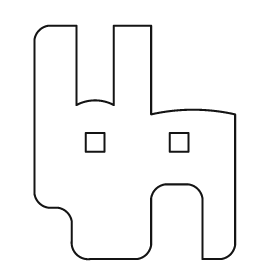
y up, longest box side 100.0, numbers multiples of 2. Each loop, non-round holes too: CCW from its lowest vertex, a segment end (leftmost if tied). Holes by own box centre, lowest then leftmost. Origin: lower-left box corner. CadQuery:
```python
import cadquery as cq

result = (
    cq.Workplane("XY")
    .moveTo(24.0, 0.0)
    .lineTo(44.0, 0.0)
    .threePointArc((48.0, 2.0), (50.0, 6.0))
    .lineTo(50.0, 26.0)
    .threePointArc((52.0, 30.0), (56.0, 32.0))
    .lineTo(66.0, 32.0)
    .threePointArc((70.0, 30.0), (72.0, 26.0))
    .lineTo(72.0, 0.0)
    .lineTo(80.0, 0.0)
    .threePointArc((84.0, 2.0), (86.0, 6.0))
    .lineTo(86.0, 62.0)
    .threePointArc((68.0, 64.0), (50.0, 62.0))
    .lineTo(50.0, 100.0)
    .lineTo(34.0, 100.0)
    .lineTo(34.0, 66.0)
    .threePointArc((26.0, 68.0), (18.0, 66.0))
    .lineTo(18.0, 100.0)
    .lineTo(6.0, 100.0)
    .threePointArc((2.0, 98.0), (0.0, 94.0))
    .lineTo(0.0, 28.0)
    .threePointArc((2.0, 24.0), (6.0, 22.0))
    .lineTo(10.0, 22.0)
    .threePointArc((14.0, 20.0), (16.0, 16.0))
    .lineTo(16.0, 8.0)
    .threePointArc((18.0, 2.0), (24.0, 0.0))
    .close()
    .moveTo(22.0, 46.0)
    .lineTo(30.0, 46.0)
    .lineTo(30.0, 54.0)
    .lineTo(22.0, 54.0)
    .close()
    .moveTo(58.0, 46.0)
    .lineTo(66.0, 46.0)
    .lineTo(66.0, 54.0)
    .lineTo(58.0, 54.0)
    .close()
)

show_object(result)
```